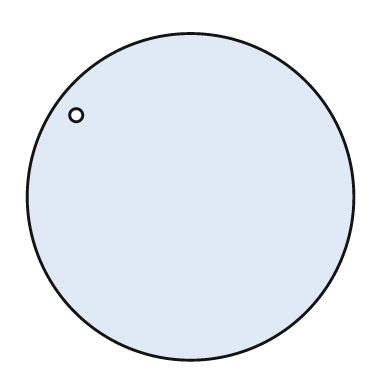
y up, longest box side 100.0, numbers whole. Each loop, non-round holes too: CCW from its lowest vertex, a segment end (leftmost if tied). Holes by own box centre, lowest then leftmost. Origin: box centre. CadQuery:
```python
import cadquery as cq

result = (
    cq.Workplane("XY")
    .moveTo(0.0, 0.0)
    .circle(50.0)
    .moveTo(-35.0, 25.0)
    .circle(2.0)
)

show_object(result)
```